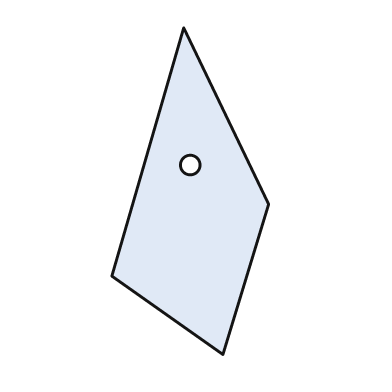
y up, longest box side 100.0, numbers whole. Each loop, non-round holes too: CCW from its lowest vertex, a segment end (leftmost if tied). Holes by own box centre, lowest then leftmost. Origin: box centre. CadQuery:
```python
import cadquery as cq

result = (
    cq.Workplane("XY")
    .moveTo(10.0, -50.0)
    .lineTo(24.0, -4.0)
    .lineTo(-2.0, 50.0)
    .lineTo(-24.0, -26.0)
    .close()
    .moveTo(0.0, 8.0)
    .circle(3.0)
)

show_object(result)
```